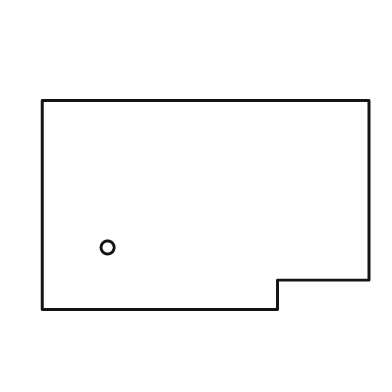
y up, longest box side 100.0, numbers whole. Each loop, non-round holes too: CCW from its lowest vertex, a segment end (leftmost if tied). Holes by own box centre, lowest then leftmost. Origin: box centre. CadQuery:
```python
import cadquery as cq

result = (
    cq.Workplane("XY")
    .moveTo(-50.0, -32.0)
    .lineTo(22.0, -32.0)
    .lineTo(22.0, -23.0)
    .lineTo(50.0, -23.0)
    .lineTo(50.0, 32.0)
    .lineTo(-50.0, 32.0)
    .close()
    .moveTo(-30.0, -13.0)
    .circle(2.0)
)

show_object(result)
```